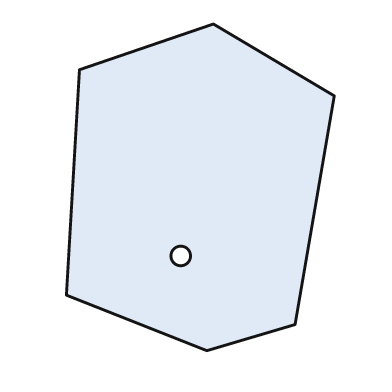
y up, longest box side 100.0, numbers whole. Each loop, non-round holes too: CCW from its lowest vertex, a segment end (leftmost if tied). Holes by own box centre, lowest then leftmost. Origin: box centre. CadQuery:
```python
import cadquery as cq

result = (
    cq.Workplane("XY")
    .moveTo(2.0, -50.0)
    .lineTo(29.0, -42.0)
    .lineTo(41.0, 28.0)
    .lineTo(4.0, 50.0)
    .lineTo(-37.0, 36.0)
    .lineTo(-41.0, -33.0)
    .close()
    .moveTo(-6.0, -21.0)
    .circle(3.0)
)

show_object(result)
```